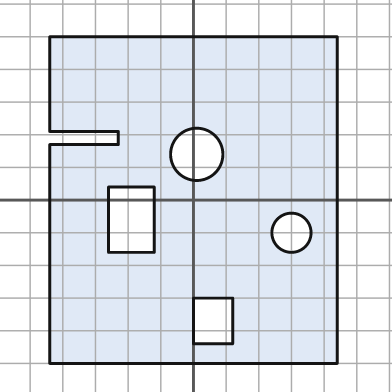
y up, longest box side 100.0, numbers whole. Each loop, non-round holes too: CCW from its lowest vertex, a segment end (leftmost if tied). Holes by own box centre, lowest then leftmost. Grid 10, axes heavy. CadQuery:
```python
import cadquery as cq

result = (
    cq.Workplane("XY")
    .moveTo(-44.0, -50.0)
    .lineTo(44.0, -50.0)
    .lineTo(44.0, 50.0)
    .lineTo(-44.0, 50.0)
    .lineTo(-44.0, 21.0)
    .lineTo(-23.0, 21.0)
    .lineTo(-23.0, 17.0)
    .lineTo(-44.0, 17.0)
    .close()
    .moveTo(0.0, -44.0)
    .lineTo(12.0, -44.0)
    .lineTo(12.0, -30.0)
    .lineTo(0.0, -30.0)
    .close()
    .moveTo(30.0, -10.0)
    .circle(6.0)
    .moveTo(-26.0, -16.0)
    .lineTo(-12.0, -16.0)
    .lineTo(-12.0, 4.0)
    .lineTo(-26.0, 4.0)
    .close()
    .moveTo(1.0, 14.0)
    .circle(8.0)
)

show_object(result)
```